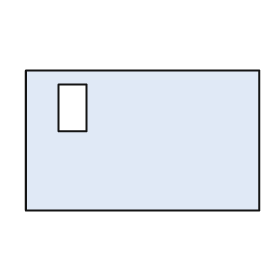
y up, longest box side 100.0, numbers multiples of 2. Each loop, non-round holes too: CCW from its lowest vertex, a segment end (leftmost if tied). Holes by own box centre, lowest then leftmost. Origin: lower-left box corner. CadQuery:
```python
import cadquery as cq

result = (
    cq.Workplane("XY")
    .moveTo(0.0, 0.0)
    .lineTo(100.0, 0.0)
    .lineTo(100.0, 60.0)
    .lineTo(0.0, 60.0)
    .close()
    .moveTo(14.0, 34.0)
    .lineTo(26.0, 34.0)
    .lineTo(26.0, 54.0)
    .lineTo(14.0, 54.0)
    .close()
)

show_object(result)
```